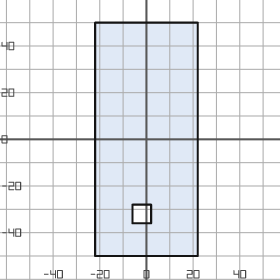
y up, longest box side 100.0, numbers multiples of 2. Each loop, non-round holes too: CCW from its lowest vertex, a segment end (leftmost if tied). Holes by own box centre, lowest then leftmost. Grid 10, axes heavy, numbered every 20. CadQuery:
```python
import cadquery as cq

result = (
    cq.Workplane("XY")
    .moveTo(-22.0, -50.0)
    .lineTo(22.0, -50.0)
    .lineTo(22.0, 50.0)
    .lineTo(-22.0, 50.0)
    .close()
    .moveTo(-6.0, -36.0)
    .lineTo(2.0, -36.0)
    .lineTo(2.0, -28.0)
    .lineTo(-6.0, -28.0)
    .close()
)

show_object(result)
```